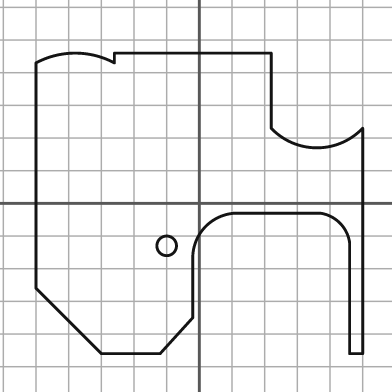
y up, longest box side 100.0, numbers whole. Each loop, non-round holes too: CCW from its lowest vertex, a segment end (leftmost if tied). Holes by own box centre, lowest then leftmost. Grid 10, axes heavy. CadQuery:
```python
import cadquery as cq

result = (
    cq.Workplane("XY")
    .moveTo(-30.0, -46.0)
    .lineTo(-12.0, -46.0)
    .lineTo(-2.0, -35.0)
    .lineTo(-2.0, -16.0)
    .threePointArc((2.0, -7.0), (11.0, -3.0))
    .lineTo(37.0, -3.0)
    .threePointArc((43.0, -6.0), (46.0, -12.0))
    .lineTo(46.0, -46.0)
    .lineTo(50.0, -46.0)
    .lineTo(50.0, 23.0)
    .threePointArc((36.0, 17.0), (22.0, 23.0))
    .lineTo(22.0, 46.0)
    .lineTo(-26.0, 46.0)
    .lineTo(-26.0, 43.0)
    .threePointArc((-38.0, 46.0), (-50.0, 43.0))
    .lineTo(-50.0, -26.0)
    .close()
    .moveTo(-10.0, -13.0)
    .circle(3.0)
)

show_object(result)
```